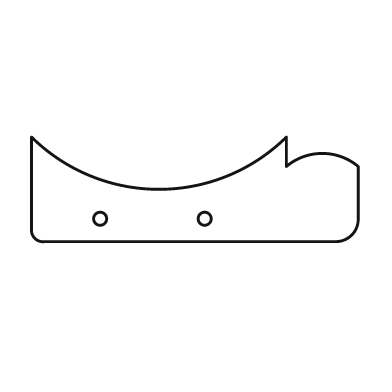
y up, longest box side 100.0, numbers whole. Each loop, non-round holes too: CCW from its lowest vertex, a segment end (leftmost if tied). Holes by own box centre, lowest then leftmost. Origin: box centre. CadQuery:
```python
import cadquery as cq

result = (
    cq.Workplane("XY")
    .moveTo(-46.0, -16.0)
    .lineTo(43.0, -16.0)
    .threePointArc((48.0, -14.0), (50.0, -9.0))
    .lineTo(50.0, 7.0)
    .threePointArc((39.0, 11.0), (28.0, 7.0))
    .lineTo(28.0, 16.0)
    .threePointArc((-11.0, 0.0), (-50.0, 16.0))
    .lineTo(-50.0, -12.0)
    .threePointArc((-49.0, -15.0), (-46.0, -16.0))
    .close()
    .moveTo(-29.0, -9.0)
    .circle(2.0)
    .moveTo(3.0, -9.0)
    .circle(2.0)
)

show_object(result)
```